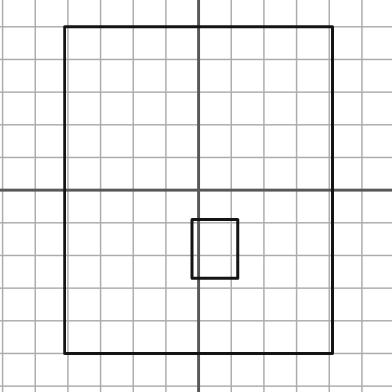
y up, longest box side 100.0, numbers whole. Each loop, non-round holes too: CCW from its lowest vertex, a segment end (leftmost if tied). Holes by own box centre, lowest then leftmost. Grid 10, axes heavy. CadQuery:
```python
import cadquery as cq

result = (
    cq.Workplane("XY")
    .moveTo(-41.0, -50.0)
    .lineTo(41.0, -50.0)
    .lineTo(41.0, 50.0)
    .lineTo(-41.0, 50.0)
    .close()
    .moveTo(-2.0, -27.0)
    .lineTo(12.0, -27.0)
    .lineTo(12.0, -9.0)
    .lineTo(-2.0, -9.0)
    .close()
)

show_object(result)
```